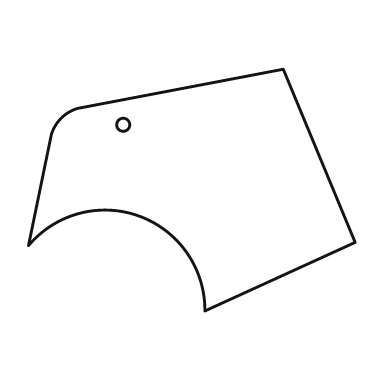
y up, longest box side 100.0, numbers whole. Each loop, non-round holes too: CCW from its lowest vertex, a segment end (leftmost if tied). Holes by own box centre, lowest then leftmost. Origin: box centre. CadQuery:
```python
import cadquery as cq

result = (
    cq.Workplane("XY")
    .moveTo(4.0, -37.0)
    .lineTo(50.0, -16.0)
    .lineTo(28.0, 37.0)
    .lineTo(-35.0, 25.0)
    .threePointArc((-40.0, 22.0), (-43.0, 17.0))
    .lineTo(-50.0, -17.0)
    .threePointArc((-16.0, -8.0), (4.0, -37.0))
    .close()
    .moveTo(-21.0, 20.0)
    .circle(2.0)
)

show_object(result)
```